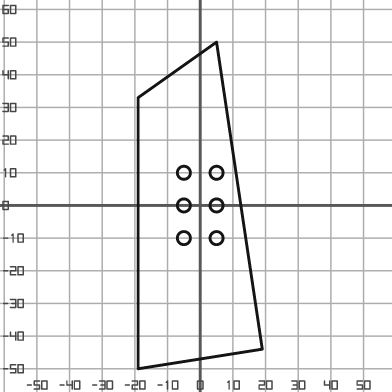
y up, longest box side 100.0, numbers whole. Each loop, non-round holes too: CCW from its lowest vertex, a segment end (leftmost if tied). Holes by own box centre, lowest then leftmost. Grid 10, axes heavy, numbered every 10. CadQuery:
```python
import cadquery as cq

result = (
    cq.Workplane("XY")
    .moveTo(-19.0, -50.0)
    .lineTo(19.0, -44.0)
    .lineTo(5.0, 50.0)
    .lineTo(-19.0, 33.0)
    .close()
    .moveTo(-5.0, -10.0)
    .circle(2.0)
    .moveTo(5.0, -10.0)
    .circle(2.0)
    .moveTo(-5.0, 0.0)
    .circle(2.0)
    .moveTo(5.0, 0.0)
    .circle(2.0)
    .moveTo(-5.0, 10.0)
    .circle(2.0)
    .moveTo(5.0, 10.0)
    .circle(2.0)
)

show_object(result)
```